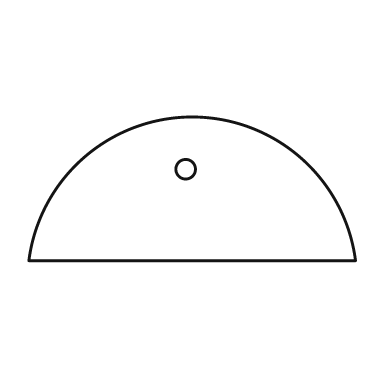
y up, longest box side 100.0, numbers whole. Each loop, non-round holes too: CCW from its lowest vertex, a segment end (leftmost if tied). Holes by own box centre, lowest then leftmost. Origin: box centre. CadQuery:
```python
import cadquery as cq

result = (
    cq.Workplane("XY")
    .moveTo(-50.0, -22.0)
    .lineTo(50.0, -22.0)
    .threePointArc((0.0, 22.0), (-50.0, -22.0))
    .close()
    .moveTo(-2.0, 6.0)
    .circle(3.0)
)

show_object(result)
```